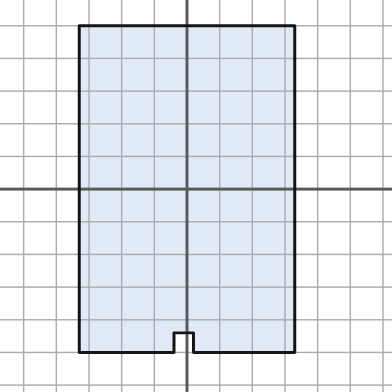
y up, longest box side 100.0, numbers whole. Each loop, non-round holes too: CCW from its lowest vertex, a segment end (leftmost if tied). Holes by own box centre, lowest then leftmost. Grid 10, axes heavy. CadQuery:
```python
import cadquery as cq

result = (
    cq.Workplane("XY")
    .moveTo(-33.0, -50.0)
    .lineTo(-4.0, -50.0)
    .lineTo(-4.0, -44.0)
    .lineTo(2.0, -44.0)
    .lineTo(2.0, -50.0)
    .lineTo(33.0, -50.0)
    .lineTo(33.0, 50.0)
    .lineTo(-33.0, 50.0)
    .close()
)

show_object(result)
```